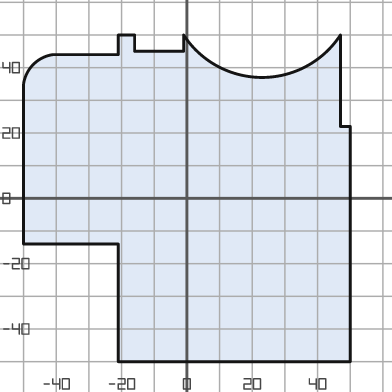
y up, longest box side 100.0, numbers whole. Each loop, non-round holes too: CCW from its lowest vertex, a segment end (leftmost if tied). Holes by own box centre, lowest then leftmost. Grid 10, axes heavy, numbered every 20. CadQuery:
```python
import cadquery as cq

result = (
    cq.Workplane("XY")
    .moveTo(-21.0, -50.0)
    .lineTo(50.0, -50.0)
    .lineTo(50.0, 22.0)
    .lineTo(47.0, 22.0)
    .lineTo(47.0, 50.0)
    .threePointArc((23.0, 37.0), (-1.0, 50.0))
    .lineTo(-1.0, 45.0)
    .lineTo(-16.0, 45.0)
    .lineTo(-16.0, 50.0)
    .lineTo(-21.0, 50.0)
    .lineTo(-21.0, 44.0)
    .lineTo(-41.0, 44.0)
    .threePointArc((-47.0, 41.0), (-50.0, 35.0))
    .lineTo(-50.0, -14.0)
    .lineTo(-21.0, -14.0)
    .close()
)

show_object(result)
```